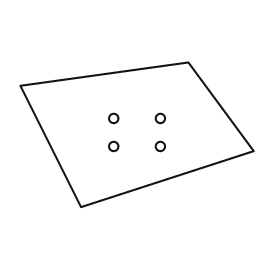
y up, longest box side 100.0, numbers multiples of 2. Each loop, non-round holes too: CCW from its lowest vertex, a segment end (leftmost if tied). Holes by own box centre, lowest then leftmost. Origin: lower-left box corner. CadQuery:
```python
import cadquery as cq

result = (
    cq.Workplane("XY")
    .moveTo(26.0, 0.0)
    .lineTo(100.0, 24.0)
    .lineTo(72.0, 62.0)
    .lineTo(0.0, 52.0)
    .close()
    .moveTo(40.0, 26.0)
    .circle(2.0)
    .moveTo(60.0, 26.0)
    .circle(2.0)
    .moveTo(40.0, 38.0)
    .circle(2.0)
    .moveTo(60.0, 38.0)
    .circle(2.0)
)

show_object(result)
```